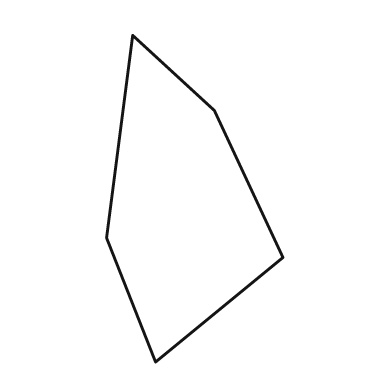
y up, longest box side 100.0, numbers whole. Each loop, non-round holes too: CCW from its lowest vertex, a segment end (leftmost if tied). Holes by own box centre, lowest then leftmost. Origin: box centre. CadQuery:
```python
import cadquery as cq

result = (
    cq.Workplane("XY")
    .moveTo(-12.0, -50.0)
    .lineTo(27.0, -18.0)
    .lineTo(6.0, 27.0)
    .lineTo(-19.0, 50.0)
    .lineTo(-27.0, -12.0)
    .close()
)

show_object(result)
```